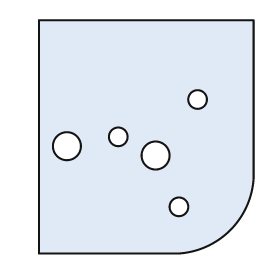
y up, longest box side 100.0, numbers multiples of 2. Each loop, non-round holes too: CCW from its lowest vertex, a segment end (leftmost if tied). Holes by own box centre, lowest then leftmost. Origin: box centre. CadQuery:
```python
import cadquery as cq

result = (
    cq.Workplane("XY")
    .moveTo(-46.0, -50.0)
    .lineTo(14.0, -50.0)
    .threePointArc((36.0, -40.0), (46.0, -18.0))
    .lineTo(46.0, 50.0)
    .lineTo(-46.0, 50.0)
    .close()
    .moveTo(14.0, -30.0)
    .circle(4.0)
    .moveTo(4.0, -8.0)
    .circle(6.0)
    .moveTo(-34.0, -4.0)
    .circle(6.0)
    .moveTo(-12.0, 0.0)
    .circle(4.0)
    .moveTo(22.0, 16.0)
    .circle(4.0)
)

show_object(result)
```